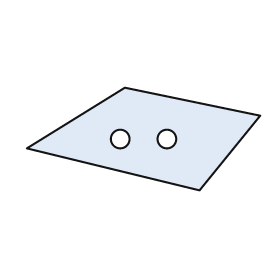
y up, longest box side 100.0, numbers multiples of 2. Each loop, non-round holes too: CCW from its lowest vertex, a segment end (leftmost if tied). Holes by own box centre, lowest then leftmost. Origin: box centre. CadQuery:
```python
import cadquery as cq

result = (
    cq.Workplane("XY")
    .moveTo(24.0, -22.0)
    .lineTo(50.0, 10.0)
    .lineTo(-8.0, 22.0)
    .lineTo(-50.0, -4.0)
    .close()
    .moveTo(-10.0, 0.0)
    .circle(4.0)
    .moveTo(10.0, 0.0)
    .circle(4.0)
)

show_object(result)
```